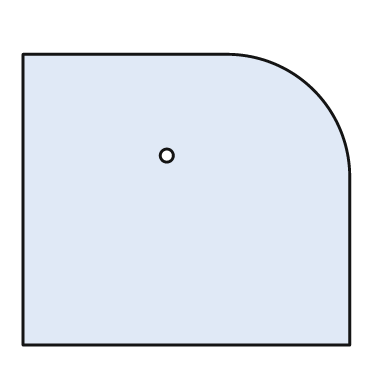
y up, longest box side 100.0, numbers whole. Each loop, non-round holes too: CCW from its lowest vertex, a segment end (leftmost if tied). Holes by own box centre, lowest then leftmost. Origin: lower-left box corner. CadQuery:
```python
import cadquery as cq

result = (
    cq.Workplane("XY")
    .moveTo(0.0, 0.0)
    .lineTo(100.0, 0.0)
    .lineTo(100.0, 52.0)
    .threePointArc((89.0, 78.0), (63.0, 89.0))
    .lineTo(0.0, 89.0)
    .close()
    .moveTo(44.0, 58.0)
    .circle(2.0)
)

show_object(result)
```